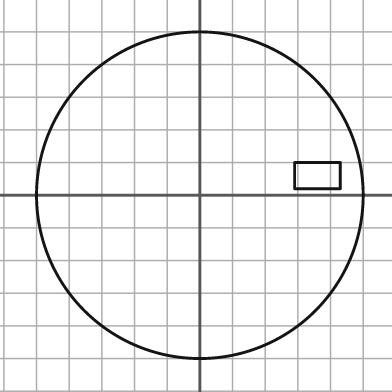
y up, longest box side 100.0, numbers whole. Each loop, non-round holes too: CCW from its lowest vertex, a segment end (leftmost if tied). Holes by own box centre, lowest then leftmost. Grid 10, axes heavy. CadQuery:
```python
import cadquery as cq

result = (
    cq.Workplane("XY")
    .moveTo(0.0, 0.0)
    .circle(50.0)
    .moveTo(29.0, 2.0)
    .lineTo(43.0, 2.0)
    .lineTo(43.0, 10.0)
    .lineTo(29.0, 10.0)
    .close()
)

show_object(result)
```